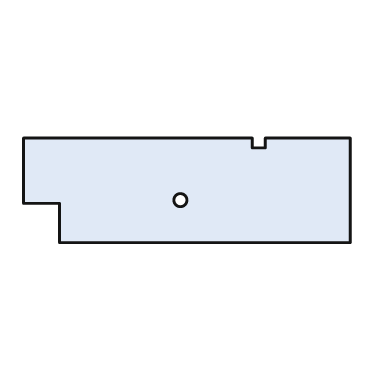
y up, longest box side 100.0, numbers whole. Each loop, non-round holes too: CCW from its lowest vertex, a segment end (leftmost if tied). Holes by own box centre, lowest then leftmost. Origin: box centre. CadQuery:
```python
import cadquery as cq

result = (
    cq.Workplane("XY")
    .moveTo(-39.0, -16.0)
    .lineTo(50.0, -16.0)
    .lineTo(50.0, 16.0)
    .lineTo(24.0, 16.0)
    .lineTo(24.0, 13.0)
    .lineTo(20.0, 13.0)
    .lineTo(20.0, 16.0)
    .lineTo(-50.0, 16.0)
    .lineTo(-50.0, -4.0)
    .lineTo(-39.0, -4.0)
    .close()
    .moveTo(-2.0, -3.0)
    .circle(2.0)
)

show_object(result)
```